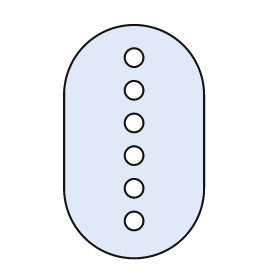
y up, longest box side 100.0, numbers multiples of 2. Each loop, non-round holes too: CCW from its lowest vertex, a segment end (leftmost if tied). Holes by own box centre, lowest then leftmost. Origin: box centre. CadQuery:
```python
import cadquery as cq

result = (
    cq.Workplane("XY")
    .moveTo(-30.0, -20.0)
    .threePointArc((0.0, -50.0), (30.0, -20.0))
    .lineTo(30.0, 20.0)
    .threePointArc((0.0, 50.0), (-30.0, 20.0))
    .close()
    .moveTo(0.0, -34.0)
    .circle(4.0)
    .moveTo(0.0, -20.0)
    .circle(4.0)
    .moveTo(0.0, -6.0)
    .circle(4.0)
    .moveTo(0.0, 8.0)
    .circle(4.0)
    .moveTo(0.0, 22.0)
    .circle(4.0)
    .moveTo(0.0, 36.0)
    .circle(4.0)
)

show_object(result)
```